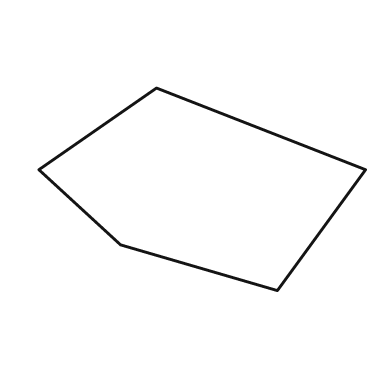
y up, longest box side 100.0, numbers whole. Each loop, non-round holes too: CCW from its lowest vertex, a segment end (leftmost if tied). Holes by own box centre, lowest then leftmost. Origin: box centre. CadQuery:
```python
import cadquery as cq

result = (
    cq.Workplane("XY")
    .moveTo(23.0, -31.0)
    .lineTo(50.0, 6.0)
    .lineTo(-14.0, 31.0)
    .lineTo(-50.0, 6.0)
    .lineTo(-25.0, -17.0)
    .close()
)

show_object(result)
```